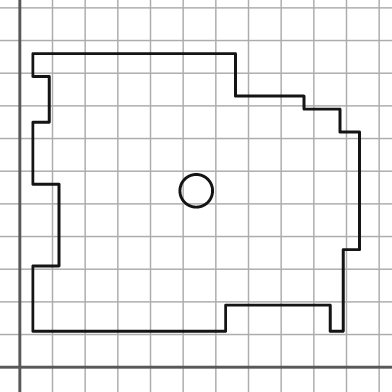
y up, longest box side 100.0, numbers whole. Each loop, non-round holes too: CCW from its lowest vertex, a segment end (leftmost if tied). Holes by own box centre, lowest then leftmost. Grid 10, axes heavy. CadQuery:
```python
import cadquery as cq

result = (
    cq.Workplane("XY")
    .moveTo(4.0, 11.0)
    .lineTo(63.0, 11.0)
    .lineTo(63.0, 19.0)
    .lineTo(95.0, 19.0)
    .lineTo(95.0, 11.0)
    .lineTo(99.0, 11.0)
    .lineTo(99.0, 36.0)
    .lineTo(104.0, 36.0)
    .lineTo(104.0, 72.0)
    .lineTo(98.0, 72.0)
    .lineTo(98.0, 79.0)
    .lineTo(87.0, 79.0)
    .lineTo(87.0, 83.0)
    .lineTo(66.0, 83.0)
    .lineTo(66.0, 96.0)
    .lineTo(4.0, 96.0)
    .lineTo(4.0, 89.0)
    .lineTo(9.0, 89.0)
    .lineTo(9.0, 75.0)
    .lineTo(4.0, 75.0)
    .lineTo(4.0, 56.0)
    .lineTo(12.0, 56.0)
    .lineTo(12.0, 31.0)
    .lineTo(4.0, 31.0)
    .close()
    .moveTo(54.0, 54.0)
    .circle(5.0)
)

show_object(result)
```